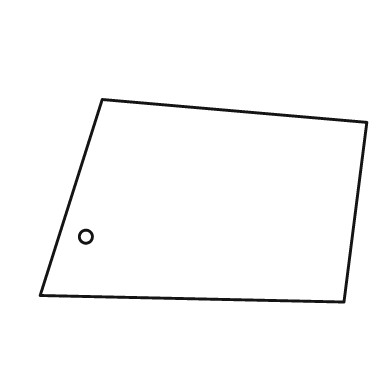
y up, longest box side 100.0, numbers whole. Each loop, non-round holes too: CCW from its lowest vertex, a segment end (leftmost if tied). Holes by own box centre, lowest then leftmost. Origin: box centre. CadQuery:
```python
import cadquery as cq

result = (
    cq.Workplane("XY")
    .moveTo(43.0, -31.0)
    .lineTo(50.0, 24.0)
    .lineTo(-31.0, 31.0)
    .lineTo(-50.0, -29.0)
    .close()
    .moveTo(-36.0, -11.0)
    .circle(2.0)
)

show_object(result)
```